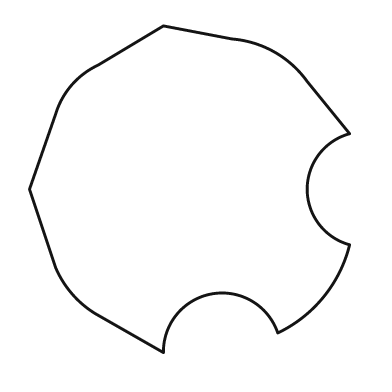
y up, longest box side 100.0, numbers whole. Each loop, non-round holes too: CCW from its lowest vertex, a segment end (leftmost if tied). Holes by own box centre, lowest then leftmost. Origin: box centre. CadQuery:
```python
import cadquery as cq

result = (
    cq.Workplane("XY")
    .moveTo(-8.0, -50.0)
    .threePointArc((7.0, -32.0), (27.0, -44.0))
    .threePointArc((41.0, -33.0), (49.0, -17.0))
    .threePointArc((36.0, 0.0), (49.0, 17.0))
    .lineTo(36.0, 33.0)
    .threePointArc((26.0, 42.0), (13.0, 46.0))
    .lineTo(-8.0, 50.0)
    .lineTo(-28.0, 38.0)
    .threePointArc((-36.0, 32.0), (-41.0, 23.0))
    .lineTo(-49.0, 0.0)
    .lineTo(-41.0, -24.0)
    .threePointArc((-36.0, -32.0), (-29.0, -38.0))
    .close()
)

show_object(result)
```